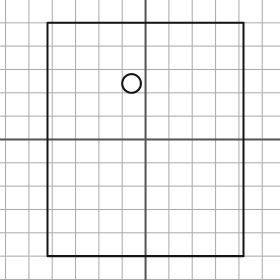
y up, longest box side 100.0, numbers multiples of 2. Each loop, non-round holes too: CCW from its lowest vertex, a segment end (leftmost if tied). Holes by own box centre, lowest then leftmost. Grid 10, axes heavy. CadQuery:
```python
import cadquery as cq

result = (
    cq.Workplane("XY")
    .moveTo(-42.0, -50.0)
    .lineTo(42.0, -50.0)
    .lineTo(42.0, 50.0)
    .lineTo(-42.0, 50.0)
    .close()
    .moveTo(-6.0, 24.0)
    .circle(4.0)
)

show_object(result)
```